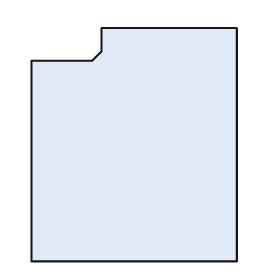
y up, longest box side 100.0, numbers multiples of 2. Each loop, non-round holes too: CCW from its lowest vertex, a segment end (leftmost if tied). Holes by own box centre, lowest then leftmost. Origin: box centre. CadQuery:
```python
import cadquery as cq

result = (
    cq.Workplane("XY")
    .moveTo(-44.0, -50.0)
    .lineTo(44.0, -50.0)
    .lineTo(44.0, 50.0)
    .lineTo(-14.0, 50.0)
    .lineTo(-14.0, 40.0)
    .lineTo(-18.0, 36.0)
    .lineTo(-44.0, 36.0)
    .close()
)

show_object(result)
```